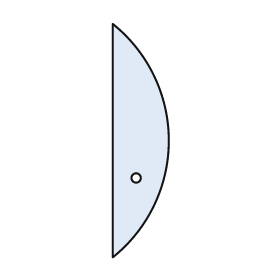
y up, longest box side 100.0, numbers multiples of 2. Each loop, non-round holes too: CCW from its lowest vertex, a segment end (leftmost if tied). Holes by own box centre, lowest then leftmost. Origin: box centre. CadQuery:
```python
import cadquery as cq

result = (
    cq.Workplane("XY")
    .moveTo(-12.0, -50.0)
    .threePointArc((12.0, 0.0), (-12.0, 50.0))
    .close()
    .moveTo(-2.0, -16.0)
    .circle(2.0)
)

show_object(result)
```